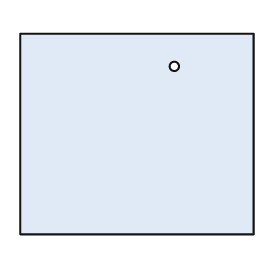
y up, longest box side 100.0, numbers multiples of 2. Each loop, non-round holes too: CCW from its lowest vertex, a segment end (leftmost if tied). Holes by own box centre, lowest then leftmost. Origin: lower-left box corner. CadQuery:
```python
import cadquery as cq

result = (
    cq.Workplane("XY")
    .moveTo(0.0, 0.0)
    .lineTo(100.0, 0.0)
    .lineTo(100.0, 86.0)
    .lineTo(0.0, 86.0)
    .close()
    .moveTo(66.0, 72.0)
    .circle(2.0)
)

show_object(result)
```